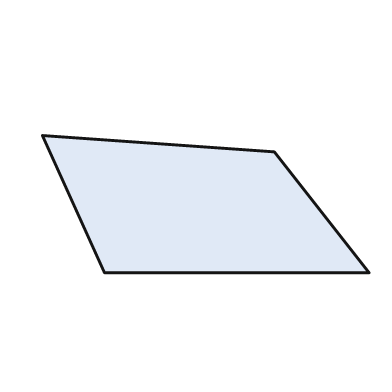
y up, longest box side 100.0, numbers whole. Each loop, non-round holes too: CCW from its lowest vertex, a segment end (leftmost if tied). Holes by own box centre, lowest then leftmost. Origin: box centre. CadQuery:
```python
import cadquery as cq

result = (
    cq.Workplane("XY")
    .moveTo(-31.0, -21.0)
    .lineTo(50.0, -21.0)
    .lineTo(21.0, 16.0)
    .lineTo(-50.0, 21.0)
    .close()
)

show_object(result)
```